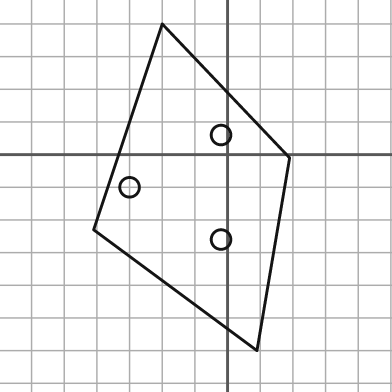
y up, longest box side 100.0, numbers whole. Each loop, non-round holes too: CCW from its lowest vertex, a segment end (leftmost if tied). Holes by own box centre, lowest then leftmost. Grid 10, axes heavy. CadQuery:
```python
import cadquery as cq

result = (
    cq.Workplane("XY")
    .moveTo(9.0, -60.0)
    .lineTo(19.0, -1.0)
    .lineTo(-20.0, 40.0)
    .lineTo(-41.0, -23.0)
    .close()
    .moveTo(-2.0, -26.0)
    .circle(3.0)
    .moveTo(-30.0, -10.0)
    .circle(3.0)
    .moveTo(-2.0, 6.0)
    .circle(3.0)
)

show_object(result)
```